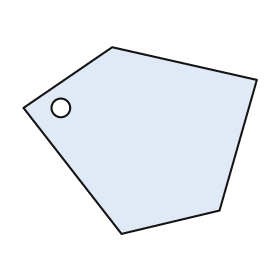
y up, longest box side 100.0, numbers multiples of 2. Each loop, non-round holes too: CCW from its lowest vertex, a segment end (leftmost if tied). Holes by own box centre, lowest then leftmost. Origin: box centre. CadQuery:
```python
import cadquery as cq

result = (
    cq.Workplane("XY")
    .moveTo(-8.0, -40.0)
    .lineTo(34.0, -30.0)
    .lineTo(50.0, 26.0)
    .lineTo(-12.0, 40.0)
    .lineTo(-50.0, 14.0)
    .close()
    .moveTo(-34.0, 14.0)
    .circle(4.0)
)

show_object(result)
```